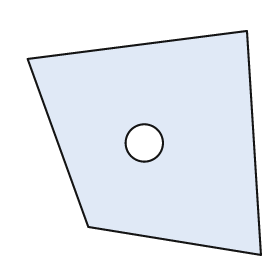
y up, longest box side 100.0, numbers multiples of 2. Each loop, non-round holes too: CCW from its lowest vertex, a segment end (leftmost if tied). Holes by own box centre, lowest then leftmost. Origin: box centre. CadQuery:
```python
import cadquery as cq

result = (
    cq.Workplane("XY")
    .moveTo(50.0, -48.0)
    .lineTo(44.0, 48.0)
    .lineTo(-50.0, 36.0)
    .lineTo(-24.0, -36.0)
    .close()
    .moveTo(0.0, 0.0)
    .circle(8.0)
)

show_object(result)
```